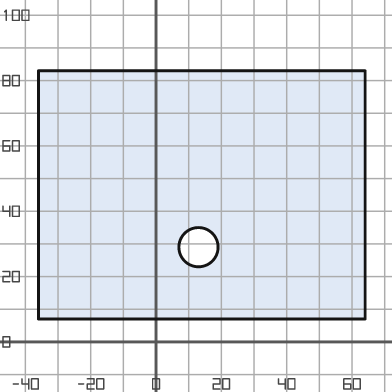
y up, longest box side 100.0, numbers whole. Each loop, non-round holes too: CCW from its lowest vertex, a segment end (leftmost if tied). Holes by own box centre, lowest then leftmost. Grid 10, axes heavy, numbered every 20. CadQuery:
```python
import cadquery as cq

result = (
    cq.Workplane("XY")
    .moveTo(-36.0, 7.0)
    .lineTo(64.0, 7.0)
    .lineTo(64.0, 83.0)
    .lineTo(-36.0, 83.0)
    .close()
    .moveTo(13.0, 29.0)
    .circle(6.0)
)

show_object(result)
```